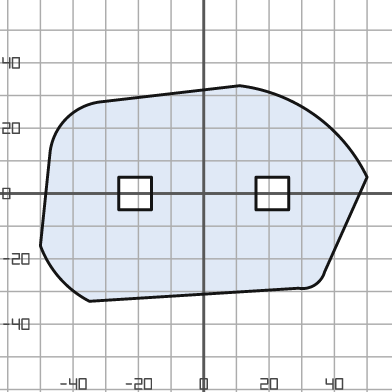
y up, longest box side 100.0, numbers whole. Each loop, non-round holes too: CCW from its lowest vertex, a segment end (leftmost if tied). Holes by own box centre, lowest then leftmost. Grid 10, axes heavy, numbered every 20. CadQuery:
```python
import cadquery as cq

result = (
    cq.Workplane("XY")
    .moveTo(-35.0, -33.0)
    .lineTo(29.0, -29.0)
    .threePointArc((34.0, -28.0), (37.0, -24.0))
    .lineTo(50.0, 5.0)
    .threePointArc((34.0, 24.0), (11.0, 33.0))
    .lineTo(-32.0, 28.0)
    .threePointArc((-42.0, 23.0), (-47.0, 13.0))
    .lineTo(-50.0, -16.0)
    .threePointArc((-44.0, -26.0), (-35.0, -33.0))
    .close()
    .moveTo(-26.0, -5.0)
    .lineTo(-16.0, -5.0)
    .lineTo(-16.0, 5.0)
    .lineTo(-26.0, 5.0)
    .close()
    .moveTo(16.0, -5.0)
    .lineTo(26.0, -5.0)
    .lineTo(26.0, 5.0)
    .lineTo(16.0, 5.0)
    .close()
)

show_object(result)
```